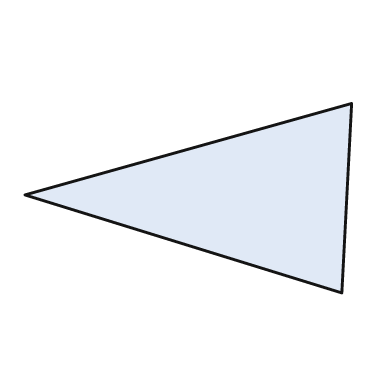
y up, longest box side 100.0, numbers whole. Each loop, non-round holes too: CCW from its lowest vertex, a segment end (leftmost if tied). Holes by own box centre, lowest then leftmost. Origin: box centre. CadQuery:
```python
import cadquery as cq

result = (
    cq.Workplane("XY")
    .moveTo(47.0, -29.0)
    .lineTo(50.0, 29.0)
    .lineTo(-50.0, 1.0)
    .close()
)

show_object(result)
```